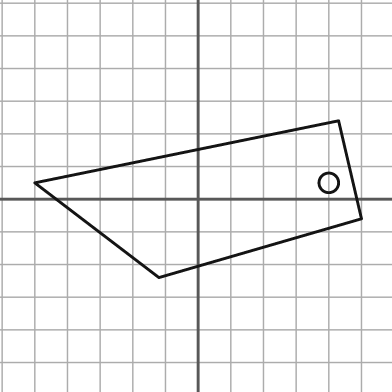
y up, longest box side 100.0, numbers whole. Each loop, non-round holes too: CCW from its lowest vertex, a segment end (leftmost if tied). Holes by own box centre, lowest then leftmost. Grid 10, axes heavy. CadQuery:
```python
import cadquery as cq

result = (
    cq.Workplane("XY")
    .moveTo(-12.0, -24.0)
    .lineTo(50.0, -6.0)
    .lineTo(43.0, 24.0)
    .lineTo(-50.0, 5.0)
    .close()
    .moveTo(40.0, 5.0)
    .circle(3.0)
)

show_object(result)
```